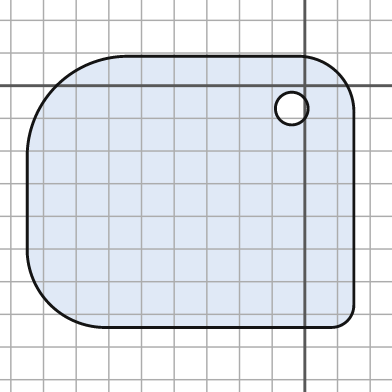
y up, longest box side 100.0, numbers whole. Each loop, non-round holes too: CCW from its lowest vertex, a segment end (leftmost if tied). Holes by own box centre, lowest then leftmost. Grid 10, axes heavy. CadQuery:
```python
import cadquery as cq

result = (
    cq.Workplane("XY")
    .moveTo(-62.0, -74.0)
    .lineTo(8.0, -74.0)
    .threePointArc((13.0, -72.0), (15.0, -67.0))
    .lineTo(15.0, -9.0)
    .threePointArc((10.0, 4.0), (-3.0, 9.0))
    .lineTo(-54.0, 9.0)
    .threePointArc((-76.0, 0.0), (-85.0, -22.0))
    .lineTo(-85.0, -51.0)
    .threePointArc((-78.0, -67.0), (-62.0, -74.0))
    .close()
    .moveTo(-4.0, -7.0)
    .circle(5.0)
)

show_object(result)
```